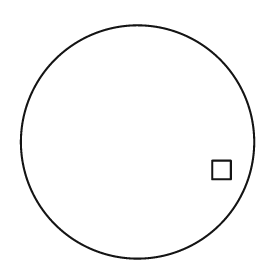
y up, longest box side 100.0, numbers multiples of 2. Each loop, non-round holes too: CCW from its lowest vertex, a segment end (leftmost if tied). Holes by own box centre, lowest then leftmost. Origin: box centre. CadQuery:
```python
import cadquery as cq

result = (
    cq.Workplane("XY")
    .moveTo(0.0, 0.0)
    .circle(50.0)
    .moveTo(32.0, -16.0)
    .lineTo(40.0, -16.0)
    .lineTo(40.0, -8.0)
    .lineTo(32.0, -8.0)
    .close()
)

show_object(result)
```